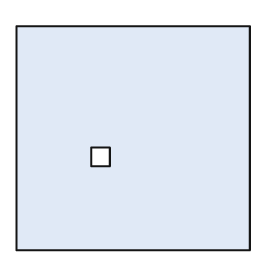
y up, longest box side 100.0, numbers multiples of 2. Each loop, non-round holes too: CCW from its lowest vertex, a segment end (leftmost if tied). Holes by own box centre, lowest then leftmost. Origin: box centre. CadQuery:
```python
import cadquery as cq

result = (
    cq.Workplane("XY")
    .moveTo(-50.0, -48.0)
    .lineTo(50.0, -48.0)
    .lineTo(50.0, 48.0)
    .lineTo(-50.0, 48.0)
    .close()
    .moveTo(-18.0, -12.0)
    .lineTo(-10.0, -12.0)
    .lineTo(-10.0, -4.0)
    .lineTo(-18.0, -4.0)
    .close()
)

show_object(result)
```